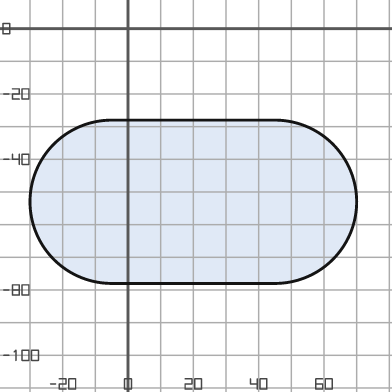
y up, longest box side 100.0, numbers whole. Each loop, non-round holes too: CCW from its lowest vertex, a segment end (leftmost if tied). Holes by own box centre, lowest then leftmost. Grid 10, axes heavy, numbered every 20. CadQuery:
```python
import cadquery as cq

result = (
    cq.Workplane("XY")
    .moveTo(-5.0, -78.0)
    .lineTo(45.0, -78.0)
    .threePointArc((70.0, -53.0), (45.0, -28.0))
    .lineTo(-5.0, -28.0)
    .threePointArc((-30.0, -53.0), (-5.0, -78.0))
    .close()
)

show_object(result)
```